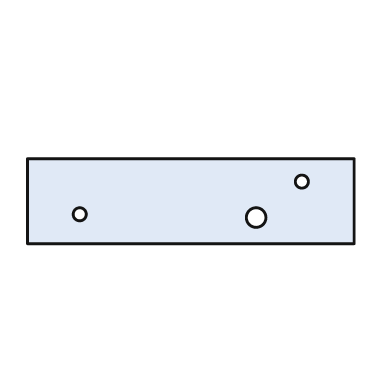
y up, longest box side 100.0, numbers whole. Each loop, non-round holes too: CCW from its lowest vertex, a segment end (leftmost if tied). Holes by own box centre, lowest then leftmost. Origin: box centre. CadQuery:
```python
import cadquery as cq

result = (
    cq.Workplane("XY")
    .moveTo(-50.0, -13.0)
    .lineTo(50.0, -13.0)
    .lineTo(50.0, 13.0)
    .lineTo(-50.0, 13.0)
    .close()
    .moveTo(20.0, -5.0)
    .circle(3.0)
    .moveTo(-34.0, -4.0)
    .circle(2.0)
    .moveTo(34.0, 6.0)
    .circle(2.0)
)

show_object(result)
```